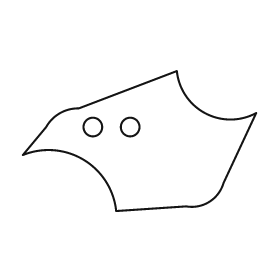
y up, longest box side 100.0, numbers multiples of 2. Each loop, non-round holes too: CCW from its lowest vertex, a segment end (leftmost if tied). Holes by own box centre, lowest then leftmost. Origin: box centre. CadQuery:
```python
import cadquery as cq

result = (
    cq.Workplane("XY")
    .moveTo(-10.0, -30.0)
    .lineTo(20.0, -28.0)
    .threePointArc((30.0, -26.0), (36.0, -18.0))
    .lineTo(50.0, 12.0)
    .threePointArc((28.0, 12.0), (16.0, 30.0))
    .lineTo(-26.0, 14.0)
    .threePointArc((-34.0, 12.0), (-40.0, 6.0))
    .lineTo(-50.0, -6.0)
    .threePointArc((-24.0, -8.0), (-10.0, -30.0))
    .close()
    .moveTo(-20.0, 6.0)
    .circle(4.0)
    .moveTo(-4.0, 6.0)
    .circle(4.0)
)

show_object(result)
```